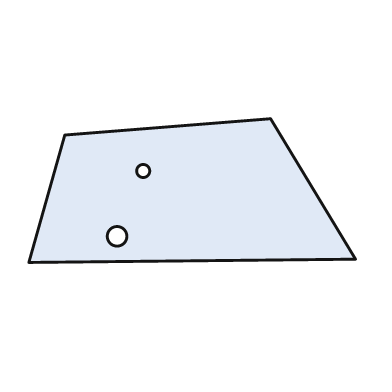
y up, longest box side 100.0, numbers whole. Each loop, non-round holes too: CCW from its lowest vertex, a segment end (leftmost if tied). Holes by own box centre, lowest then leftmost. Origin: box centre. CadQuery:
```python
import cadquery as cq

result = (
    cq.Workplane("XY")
    .moveTo(-50.0, -22.0)
    .lineTo(50.0, -21.0)
    .lineTo(24.0, 22.0)
    .lineTo(-39.0, 17.0)
    .close()
    .moveTo(-23.0, -14.0)
    .circle(3.0)
    .moveTo(-15.0, 6.0)
    .circle(2.0)
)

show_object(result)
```